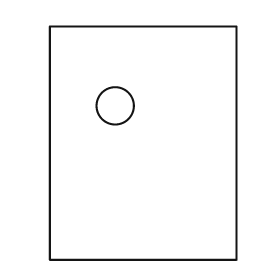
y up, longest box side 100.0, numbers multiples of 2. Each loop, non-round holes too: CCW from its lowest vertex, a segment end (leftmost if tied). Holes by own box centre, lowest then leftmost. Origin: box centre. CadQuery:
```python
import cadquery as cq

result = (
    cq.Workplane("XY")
    .moveTo(-40.0, -50.0)
    .lineTo(40.0, -50.0)
    .lineTo(40.0, 50.0)
    .lineTo(-40.0, 50.0)
    .close()
    .moveTo(-12.0, 16.0)
    .circle(8.0)
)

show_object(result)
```